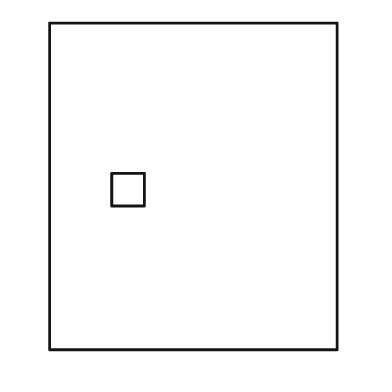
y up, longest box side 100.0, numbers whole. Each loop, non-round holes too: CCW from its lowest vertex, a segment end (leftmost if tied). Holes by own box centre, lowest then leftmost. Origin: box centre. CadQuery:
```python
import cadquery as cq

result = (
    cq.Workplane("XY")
    .moveTo(-44.0, -50.0)
    .lineTo(44.0, -50.0)
    .lineTo(44.0, 50.0)
    .lineTo(-44.0, 50.0)
    .close()
    .moveTo(-25.0, -6.0)
    .lineTo(-15.0, -6.0)
    .lineTo(-15.0, 4.0)
    .lineTo(-25.0, 4.0)
    .close()
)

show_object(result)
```